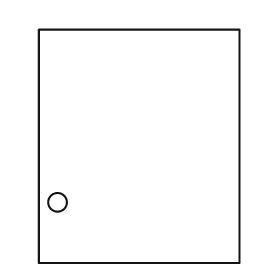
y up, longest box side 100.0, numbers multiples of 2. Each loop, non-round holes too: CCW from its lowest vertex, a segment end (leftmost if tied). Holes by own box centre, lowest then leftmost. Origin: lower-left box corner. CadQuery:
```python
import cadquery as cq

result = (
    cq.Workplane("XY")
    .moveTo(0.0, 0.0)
    .lineTo(86.0, 0.0)
    .lineTo(86.0, 100.0)
    .lineTo(0.0, 100.0)
    .close()
    .moveTo(8.0, 26.0)
    .circle(4.0)
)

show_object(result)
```